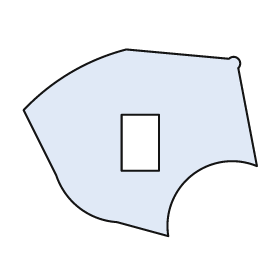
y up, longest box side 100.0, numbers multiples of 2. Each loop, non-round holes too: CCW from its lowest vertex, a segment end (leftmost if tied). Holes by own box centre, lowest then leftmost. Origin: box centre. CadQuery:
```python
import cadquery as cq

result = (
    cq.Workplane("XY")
    .moveTo(12.0, -40.0)
    .threePointArc((22.0, -14.0), (50.0, -10.0))
    .lineTo(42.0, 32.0)
    .threePointArc((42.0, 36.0), (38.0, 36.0))
    .lineTo(-6.0, 40.0)
    .threePointArc((-30.0, 30.0), (-50.0, 14.0))
    .lineTo(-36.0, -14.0)
    .threePointArc((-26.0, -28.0), (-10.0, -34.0))
    .close()
    .moveTo(-8.0, -12.0)
    .lineTo(8.0, -12.0)
    .lineTo(8.0, 12.0)
    .lineTo(-8.0, 12.0)
    .close()
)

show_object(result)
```